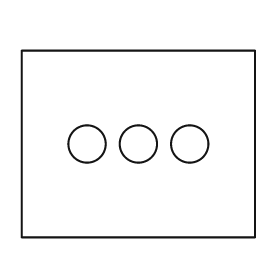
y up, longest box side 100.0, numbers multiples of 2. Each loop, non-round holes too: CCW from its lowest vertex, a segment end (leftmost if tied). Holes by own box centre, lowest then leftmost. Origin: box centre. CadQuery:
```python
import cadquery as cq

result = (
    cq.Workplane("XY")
    .moveTo(-50.0, -40.0)
    .lineTo(50.0, -40.0)
    .lineTo(50.0, 40.0)
    .lineTo(-50.0, 40.0)
    .close()
    .moveTo(-22.0, 0.0)
    .circle(8.0)
    .moveTo(0.0, 0.0)
    .circle(8.0)
    .moveTo(22.0, 0.0)
    .circle(8.0)
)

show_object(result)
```